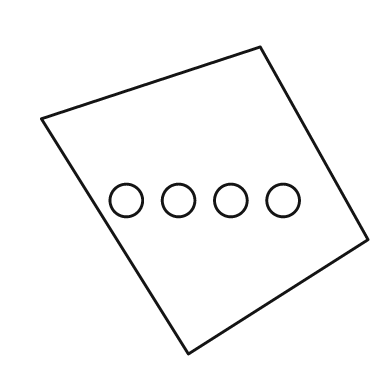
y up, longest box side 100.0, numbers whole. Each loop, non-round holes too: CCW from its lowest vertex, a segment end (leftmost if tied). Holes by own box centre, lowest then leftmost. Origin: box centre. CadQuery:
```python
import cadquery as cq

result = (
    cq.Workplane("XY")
    .moveTo(-5.0, -47.0)
    .lineTo(50.0, -12.0)
    .lineTo(17.0, 47.0)
    .lineTo(-50.0, 25.0)
    .close()
    .moveTo(-24.0, 0.0)
    .circle(5.0)
    .moveTo(-8.0, 0.0)
    .circle(5.0)
    .moveTo(8.0, 0.0)
    .circle(5.0)
    .moveTo(24.0, 0.0)
    .circle(5.0)
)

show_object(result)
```